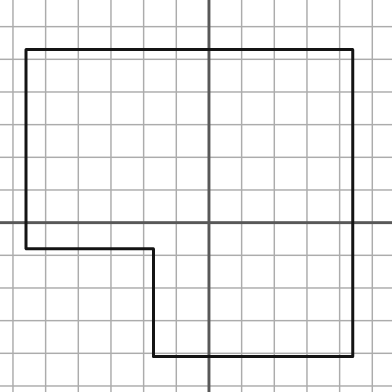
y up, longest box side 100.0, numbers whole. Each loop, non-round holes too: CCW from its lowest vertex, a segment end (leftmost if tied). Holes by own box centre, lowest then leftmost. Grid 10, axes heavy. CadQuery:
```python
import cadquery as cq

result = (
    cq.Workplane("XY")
    .moveTo(-17.0, -41.0)
    .lineTo(44.0, -41.0)
    .lineTo(44.0, 53.0)
    .lineTo(-56.0, 53.0)
    .lineTo(-56.0, -8.0)
    .lineTo(-17.0, -8.0)
    .close()
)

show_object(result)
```